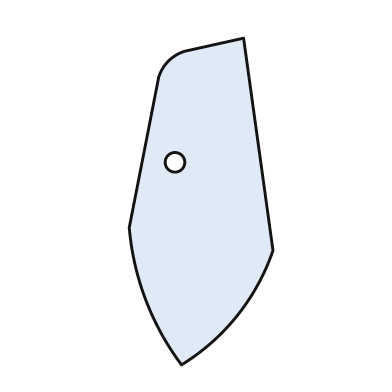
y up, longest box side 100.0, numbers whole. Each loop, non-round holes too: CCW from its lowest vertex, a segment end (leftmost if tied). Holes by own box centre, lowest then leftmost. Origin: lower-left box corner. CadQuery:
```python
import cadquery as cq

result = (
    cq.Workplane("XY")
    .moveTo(16.0, 0.0)
    .threePointArc((33.0, 15.0), (44.0, 35.0))
    .lineTo(35.0, 100.0)
    .lineTo(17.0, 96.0)
    .threePointArc((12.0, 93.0), (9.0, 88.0))
    .lineTo(0.0, 42.0)
    .threePointArc((5.0, 20.0), (16.0, 0.0))
    .close()
    .moveTo(14.0, 62.0)
    .circle(3.0)
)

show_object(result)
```